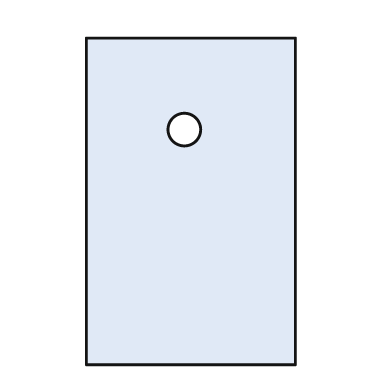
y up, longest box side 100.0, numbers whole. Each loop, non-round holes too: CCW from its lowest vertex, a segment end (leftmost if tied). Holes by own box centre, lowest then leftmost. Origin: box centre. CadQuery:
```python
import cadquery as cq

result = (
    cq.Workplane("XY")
    .moveTo(-32.0, -50.0)
    .lineTo(32.0, -50.0)
    .lineTo(32.0, 50.0)
    .lineTo(-32.0, 50.0)
    .close()
    .moveTo(-2.0, 22.0)
    .circle(5.0)
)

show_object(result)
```